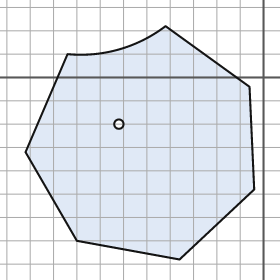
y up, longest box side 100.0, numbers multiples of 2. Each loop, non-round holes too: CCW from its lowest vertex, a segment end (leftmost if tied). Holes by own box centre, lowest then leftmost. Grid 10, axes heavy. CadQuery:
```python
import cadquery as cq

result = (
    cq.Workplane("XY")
    .moveTo(-36.0, -78.0)
    .lineTo(-4.0, -48.0)
    .lineTo(-6.0, -4.0)
    .lineTo(-42.0, 22.0)
    .threePointArc((-62.0, 12.0), (-84.0, 10.0))
    .lineTo(-102.0, -32.0)
    .lineTo(-80.0, -70.0)
    .close()
    .moveTo(-62.0, -20.0)
    .circle(2.0)
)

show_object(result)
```